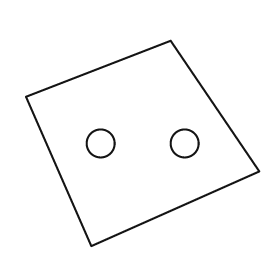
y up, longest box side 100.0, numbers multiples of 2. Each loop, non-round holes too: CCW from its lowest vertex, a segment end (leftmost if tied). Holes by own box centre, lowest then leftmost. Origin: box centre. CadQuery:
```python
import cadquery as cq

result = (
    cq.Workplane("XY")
    .moveTo(-22.0, -44.0)
    .lineTo(50.0, -12.0)
    .lineTo(12.0, 44.0)
    .lineTo(-50.0, 20.0)
    .close()
    .moveTo(-18.0, 0.0)
    .circle(6.0)
    .moveTo(18.0, 0.0)
    .circle(6.0)
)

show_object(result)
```